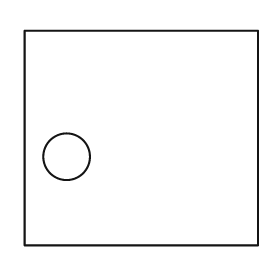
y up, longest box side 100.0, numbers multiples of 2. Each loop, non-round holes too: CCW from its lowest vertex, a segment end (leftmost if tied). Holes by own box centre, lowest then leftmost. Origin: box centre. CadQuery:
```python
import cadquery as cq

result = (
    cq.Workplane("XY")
    .moveTo(-50.0, -46.0)
    .lineTo(50.0, -46.0)
    .lineTo(50.0, 46.0)
    .lineTo(-50.0, 46.0)
    .close()
    .moveTo(-32.0, -8.0)
    .circle(10.0)
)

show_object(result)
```